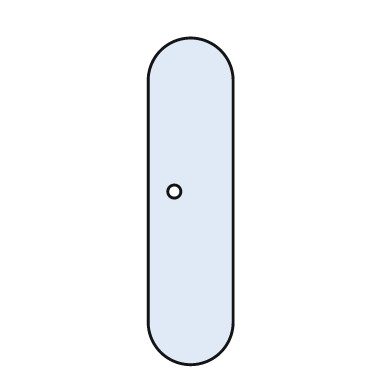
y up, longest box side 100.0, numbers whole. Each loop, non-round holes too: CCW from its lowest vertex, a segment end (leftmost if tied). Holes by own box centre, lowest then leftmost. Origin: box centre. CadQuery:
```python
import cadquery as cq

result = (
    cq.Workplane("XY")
    .moveTo(-13.0, -37.0)
    .threePointArc((0.0, -50.0), (13.0, -37.0))
    .lineTo(13.0, 37.0)
    .threePointArc((0.0, 50.0), (-13.0, 37.0))
    .close()
    .moveTo(-5.0, 3.0)
    .circle(2.0)
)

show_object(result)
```